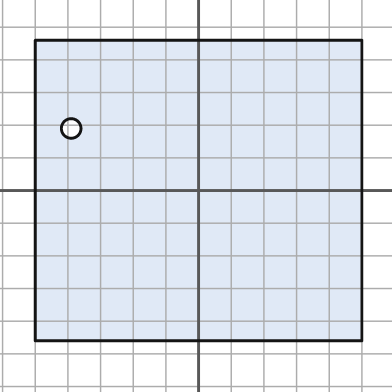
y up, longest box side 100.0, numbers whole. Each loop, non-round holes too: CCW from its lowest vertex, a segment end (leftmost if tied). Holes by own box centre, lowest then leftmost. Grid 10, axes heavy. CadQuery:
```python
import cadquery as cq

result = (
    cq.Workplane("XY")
    .moveTo(-50.0, -46.0)
    .lineTo(50.0, -46.0)
    .lineTo(50.0, 46.0)
    .lineTo(-50.0, 46.0)
    .close()
    .moveTo(-39.0, 19.0)
    .circle(3.0)
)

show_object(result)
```